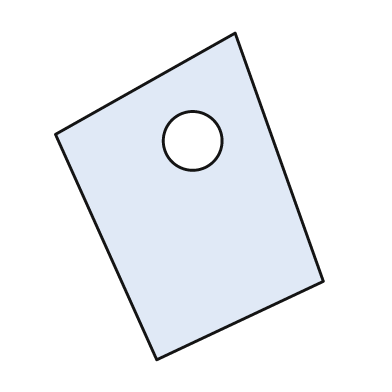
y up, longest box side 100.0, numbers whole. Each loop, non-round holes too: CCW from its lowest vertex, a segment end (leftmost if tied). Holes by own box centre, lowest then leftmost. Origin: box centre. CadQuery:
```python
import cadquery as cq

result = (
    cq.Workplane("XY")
    .moveTo(-10.0, -50.0)
    .lineTo(41.0, -26.0)
    .lineTo(14.0, 50.0)
    .lineTo(-41.0, 19.0)
    .close()
    .moveTo(1.0, 17.0)
    .circle(9.0)
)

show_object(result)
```